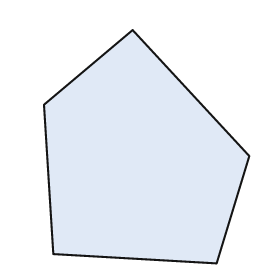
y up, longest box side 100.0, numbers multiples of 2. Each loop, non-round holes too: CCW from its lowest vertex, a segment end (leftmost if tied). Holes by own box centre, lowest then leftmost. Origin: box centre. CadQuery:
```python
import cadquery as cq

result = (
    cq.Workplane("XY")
    .moveTo(30.0, -50.0)
    .lineTo(44.0, -4.0)
    .lineTo(-6.0, 50.0)
    .lineTo(-44.0, 18.0)
    .lineTo(-40.0, -46.0)
    .close()
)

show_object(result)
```